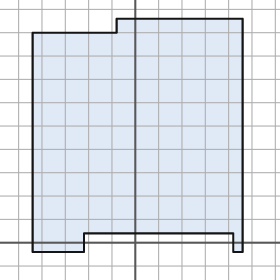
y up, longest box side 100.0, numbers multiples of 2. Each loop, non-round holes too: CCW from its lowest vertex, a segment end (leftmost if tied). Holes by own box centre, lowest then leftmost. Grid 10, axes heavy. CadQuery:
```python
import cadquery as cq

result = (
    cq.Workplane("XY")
    .moveTo(-44.0, -4.0)
    .lineTo(-22.0, -4.0)
    .lineTo(-22.0, 4.0)
    .lineTo(42.0, 4.0)
    .lineTo(42.0, -4.0)
    .lineTo(46.0, -4.0)
    .lineTo(46.0, 96.0)
    .lineTo(-8.0, 96.0)
    .lineTo(-8.0, 90.0)
    .lineTo(-44.0, 90.0)
    .close()
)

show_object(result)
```